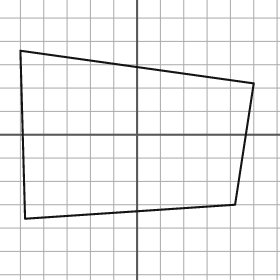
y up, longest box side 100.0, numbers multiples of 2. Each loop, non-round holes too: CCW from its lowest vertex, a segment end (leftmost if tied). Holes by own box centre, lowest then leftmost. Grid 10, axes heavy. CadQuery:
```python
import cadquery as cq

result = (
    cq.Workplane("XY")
    .moveTo(-48.0, -36.0)
    .lineTo(42.0, -30.0)
    .lineTo(50.0, 22.0)
    .lineTo(-50.0, 36.0)
    .close()
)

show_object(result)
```